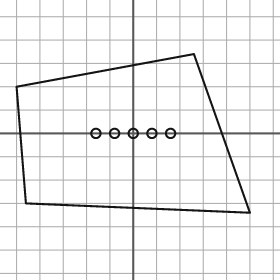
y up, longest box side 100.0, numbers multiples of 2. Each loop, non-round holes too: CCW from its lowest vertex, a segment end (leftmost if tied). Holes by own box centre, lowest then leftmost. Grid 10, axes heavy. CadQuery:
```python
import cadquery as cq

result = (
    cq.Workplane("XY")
    .moveTo(50.0, -34.0)
    .lineTo(26.0, 34.0)
    .lineTo(-50.0, 20.0)
    .lineTo(-46.0, -30.0)
    .close()
    .moveTo(-16.0, 0.0)
    .circle(2.0)
    .moveTo(-8.0, 0.0)
    .circle(2.0)
    .moveTo(0.0, 0.0)
    .circle(2.0)
    .moveTo(8.0, 0.0)
    .circle(2.0)
    .moveTo(16.0, 0.0)
    .circle(2.0)
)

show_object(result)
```